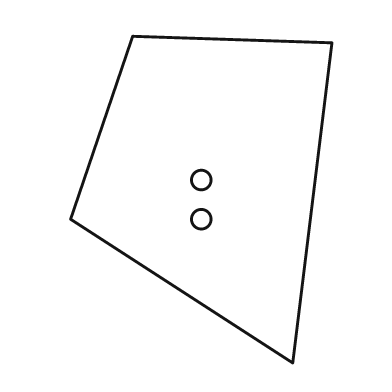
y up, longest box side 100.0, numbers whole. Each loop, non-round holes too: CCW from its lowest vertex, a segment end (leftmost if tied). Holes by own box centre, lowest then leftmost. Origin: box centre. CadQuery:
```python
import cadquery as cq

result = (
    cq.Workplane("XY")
    .moveTo(28.0, -50.0)
    .lineTo(40.0, 48.0)
    .lineTo(-21.0, 50.0)
    .lineTo(-40.0, -6.0)
    .close()
    .moveTo(0.0, -6.0)
    .circle(3.0)
    .moveTo(0.0, 6.0)
    .circle(3.0)
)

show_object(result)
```